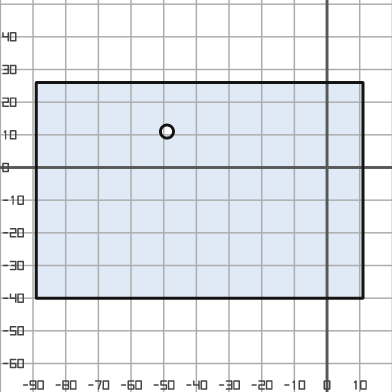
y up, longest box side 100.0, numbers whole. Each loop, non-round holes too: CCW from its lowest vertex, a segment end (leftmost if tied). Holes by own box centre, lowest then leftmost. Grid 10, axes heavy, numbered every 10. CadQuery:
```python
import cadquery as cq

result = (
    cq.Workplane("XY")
    .moveTo(-89.0, -40.0)
    .lineTo(11.0, -40.0)
    .lineTo(11.0, 26.0)
    .lineTo(-89.0, 26.0)
    .close()
    .moveTo(-49.0, 11.0)
    .circle(2.0)
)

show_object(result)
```